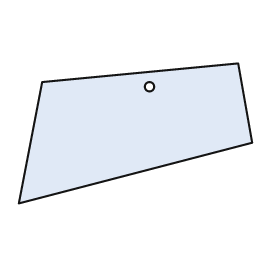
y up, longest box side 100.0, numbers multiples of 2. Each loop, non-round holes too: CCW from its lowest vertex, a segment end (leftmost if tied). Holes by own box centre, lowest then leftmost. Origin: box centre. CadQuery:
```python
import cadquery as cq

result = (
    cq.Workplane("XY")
    .moveTo(-50.0, -30.0)
    .lineTo(50.0, -4.0)
    .lineTo(44.0, 30.0)
    .lineTo(-40.0, 22.0)
    .close()
    .moveTo(6.0, 20.0)
    .circle(2.0)
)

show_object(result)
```